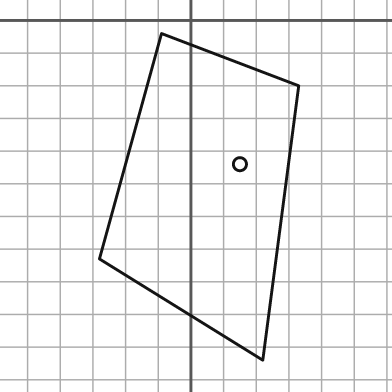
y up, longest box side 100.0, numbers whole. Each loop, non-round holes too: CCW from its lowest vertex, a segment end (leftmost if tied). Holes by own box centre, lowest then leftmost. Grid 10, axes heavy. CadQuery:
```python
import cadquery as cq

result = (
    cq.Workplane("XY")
    .moveTo(22.0, -104.0)
    .lineTo(33.0, -20.0)
    .lineTo(-9.0, -4.0)
    .lineTo(-28.0, -73.0)
    .close()
    .moveTo(15.0, -44.0)
    .circle(2.0)
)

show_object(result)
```